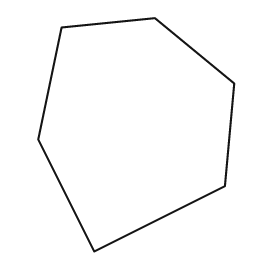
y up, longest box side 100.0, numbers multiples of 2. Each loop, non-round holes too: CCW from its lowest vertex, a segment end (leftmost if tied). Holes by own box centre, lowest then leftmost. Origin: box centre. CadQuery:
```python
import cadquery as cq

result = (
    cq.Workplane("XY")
    .moveTo(-18.0, -50.0)
    .lineTo(38.0, -22.0)
    .lineTo(42.0, 22.0)
    .lineTo(8.0, 50.0)
    .lineTo(-32.0, 46.0)
    .lineTo(-42.0, -2.0)
    .close()
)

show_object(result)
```